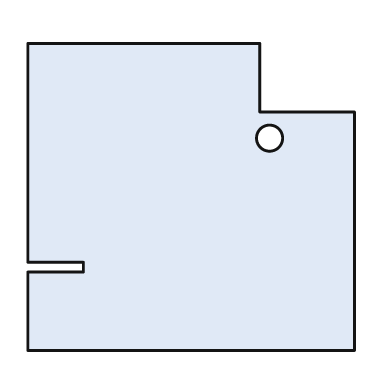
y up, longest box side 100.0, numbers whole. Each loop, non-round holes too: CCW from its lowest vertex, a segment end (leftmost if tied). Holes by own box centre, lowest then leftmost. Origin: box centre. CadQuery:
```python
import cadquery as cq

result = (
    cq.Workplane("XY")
    .moveTo(-50.0, -47.0)
    .lineTo(50.0, -47.0)
    .lineTo(50.0, 26.0)
    .lineTo(21.0, 26.0)
    .lineTo(21.0, 47.0)
    .lineTo(-50.0, 47.0)
    .lineTo(-50.0, -20.0)
    .lineTo(-33.0, -20.0)
    .lineTo(-33.0, -23.0)
    .lineTo(-50.0, -23.0)
    .close()
    .moveTo(24.0, 18.0)
    .circle(4.0)
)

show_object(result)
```